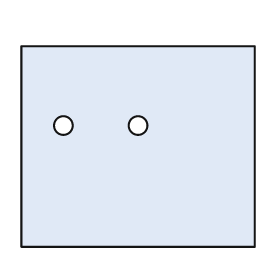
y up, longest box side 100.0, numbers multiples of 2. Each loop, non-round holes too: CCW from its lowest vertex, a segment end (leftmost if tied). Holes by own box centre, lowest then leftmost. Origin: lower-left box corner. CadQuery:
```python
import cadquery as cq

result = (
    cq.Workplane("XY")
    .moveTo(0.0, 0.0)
    .lineTo(100.0, 0.0)
    .lineTo(100.0, 86.0)
    .lineTo(0.0, 86.0)
    .close()
    .moveTo(18.0, 52.0)
    .circle(4.0)
    .moveTo(50.0, 52.0)
    .circle(4.0)
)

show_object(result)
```